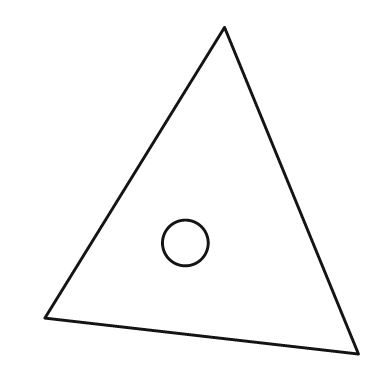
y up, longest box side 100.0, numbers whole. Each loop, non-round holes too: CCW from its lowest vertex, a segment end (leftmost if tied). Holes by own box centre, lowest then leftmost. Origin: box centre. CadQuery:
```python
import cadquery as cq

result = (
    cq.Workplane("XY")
    .moveTo(48.0, -50.0)
    .lineTo(7.0, 50.0)
    .lineTo(-48.0, -39.0)
    .close()
    .moveTo(-5.0, -16.0)
    .circle(7.0)
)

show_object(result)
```